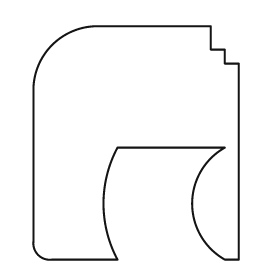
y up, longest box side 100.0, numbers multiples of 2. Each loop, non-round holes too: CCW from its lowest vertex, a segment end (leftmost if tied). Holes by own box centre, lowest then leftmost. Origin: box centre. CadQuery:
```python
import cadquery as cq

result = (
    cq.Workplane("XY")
    .moveTo(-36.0, -50.0)
    .lineTo(-8.0, -50.0)
    .threePointArc((-14.0, -26.0), (-8.0, -2.0))
    .lineTo(38.0, -2.0)
    .threePointArc((24.0, -26.0), (38.0, -50.0))
    .lineTo(44.0, -50.0)
    .lineTo(44.0, 34.0)
    .lineTo(38.0, 34.0)
    .lineTo(38.0, 40.0)
    .lineTo(32.0, 40.0)
    .lineTo(32.0, 50.0)
    .lineTo(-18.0, 50.0)
    .threePointArc((-36.0, 42.0), (-44.0, 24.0))
    .lineTo(-44.0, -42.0)
    .threePointArc((-42.0, -48.0), (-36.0, -50.0))
    .close()
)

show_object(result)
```